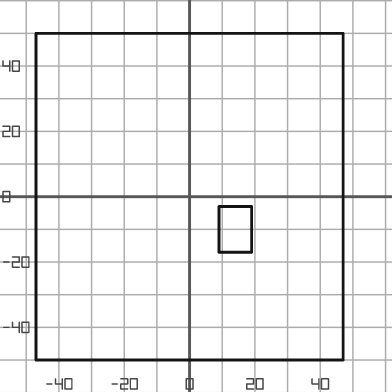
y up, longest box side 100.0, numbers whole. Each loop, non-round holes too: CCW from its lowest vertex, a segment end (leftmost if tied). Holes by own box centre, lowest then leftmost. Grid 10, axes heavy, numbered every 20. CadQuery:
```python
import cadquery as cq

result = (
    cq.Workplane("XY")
    .moveTo(-47.0, -50.0)
    .lineTo(47.0, -50.0)
    .lineTo(47.0, 50.0)
    .lineTo(-47.0, 50.0)
    .close()
    .moveTo(9.0, -17.0)
    .lineTo(19.0, -17.0)
    .lineTo(19.0, -3.0)
    .lineTo(9.0, -3.0)
    .close()
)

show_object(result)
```